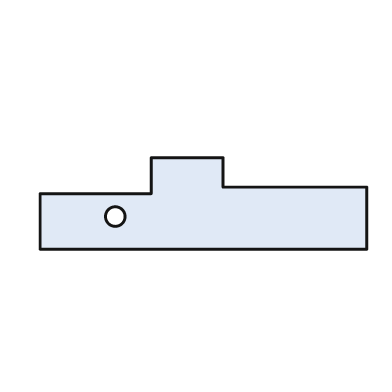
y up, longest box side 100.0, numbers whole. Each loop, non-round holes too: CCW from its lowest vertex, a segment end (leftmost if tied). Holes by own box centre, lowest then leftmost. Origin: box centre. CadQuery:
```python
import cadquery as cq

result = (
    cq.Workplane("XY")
    .moveTo(-50.0, -14.0)
    .lineTo(50.0, -14.0)
    .lineTo(50.0, 5.0)
    .lineTo(6.0, 5.0)
    .lineTo(6.0, 14.0)
    .lineTo(-16.0, 14.0)
    .lineTo(-16.0, 3.0)
    .lineTo(-50.0, 3.0)
    .close()
    .moveTo(-27.0, -4.0)
    .circle(3.0)
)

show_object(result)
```